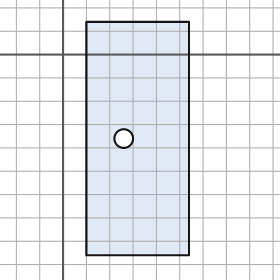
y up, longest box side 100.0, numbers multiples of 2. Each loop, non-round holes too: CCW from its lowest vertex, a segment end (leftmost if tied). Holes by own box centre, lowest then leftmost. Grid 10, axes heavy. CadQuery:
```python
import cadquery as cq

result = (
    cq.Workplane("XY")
    .moveTo(10.0, -86.0)
    .lineTo(54.0, -86.0)
    .lineTo(54.0, 14.0)
    .lineTo(10.0, 14.0)
    .close()
    .moveTo(26.0, -36.0)
    .circle(4.0)
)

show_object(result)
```